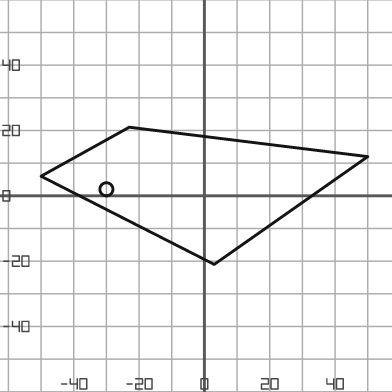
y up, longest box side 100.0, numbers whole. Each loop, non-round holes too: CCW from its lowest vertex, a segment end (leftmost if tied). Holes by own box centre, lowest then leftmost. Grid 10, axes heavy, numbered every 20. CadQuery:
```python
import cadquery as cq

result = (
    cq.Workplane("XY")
    .moveTo(3.0, -21.0)
    .lineTo(50.0, 12.0)
    .lineTo(-23.0, 21.0)
    .lineTo(-50.0, 6.0)
    .close()
    .moveTo(-30.0, 2.0)
    .circle(2.0)
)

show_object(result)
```